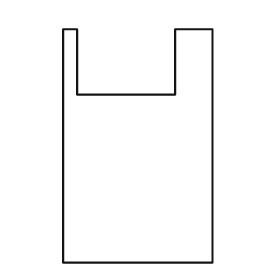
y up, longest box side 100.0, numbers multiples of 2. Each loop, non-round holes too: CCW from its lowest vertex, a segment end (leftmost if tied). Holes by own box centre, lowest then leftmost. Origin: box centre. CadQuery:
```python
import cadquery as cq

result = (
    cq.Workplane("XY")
    .moveTo(-32.0, -50.0)
    .lineTo(32.0, -50.0)
    .lineTo(32.0, 50.0)
    .lineTo(16.0, 50.0)
    .lineTo(16.0, 22.0)
    .lineTo(-26.0, 22.0)
    .lineTo(-26.0, 50.0)
    .lineTo(-32.0, 50.0)
    .close()
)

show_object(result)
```